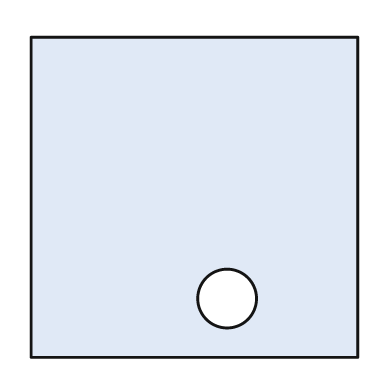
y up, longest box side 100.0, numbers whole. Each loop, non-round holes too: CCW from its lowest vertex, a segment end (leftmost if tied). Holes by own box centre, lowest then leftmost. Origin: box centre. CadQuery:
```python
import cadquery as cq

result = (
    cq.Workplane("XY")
    .moveTo(-50.0, -49.0)
    .lineTo(50.0, -49.0)
    .lineTo(50.0, 49.0)
    .lineTo(-50.0, 49.0)
    .close()
    .moveTo(10.0, -31.0)
    .circle(9.0)
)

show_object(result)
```